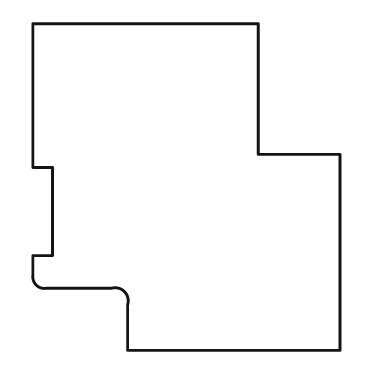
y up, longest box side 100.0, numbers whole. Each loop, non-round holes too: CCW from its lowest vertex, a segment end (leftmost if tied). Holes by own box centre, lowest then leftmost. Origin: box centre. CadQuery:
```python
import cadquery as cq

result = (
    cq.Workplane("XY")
    .moveTo(-18.0, -50.0)
    .lineTo(47.0, -50.0)
    .lineTo(47.0, 10.0)
    .lineTo(22.0, 10.0)
    .lineTo(22.0, 50.0)
    .lineTo(-47.0, 50.0)
    .lineTo(-47.0, 6.0)
    .lineTo(-41.0, 6.0)
    .lineTo(-41.0, -21.0)
    .lineTo(-47.0, -21.0)
    .lineTo(-47.0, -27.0)
    .threePointArc((-46.0, -30.0), (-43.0, -31.0))
    .lineTo(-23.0, -31.0)
    .threePointArc((-19.0, -32.0), (-18.0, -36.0))
    .close()
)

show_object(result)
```